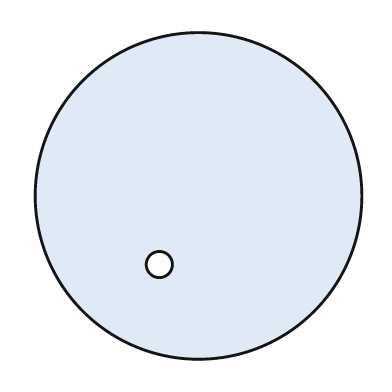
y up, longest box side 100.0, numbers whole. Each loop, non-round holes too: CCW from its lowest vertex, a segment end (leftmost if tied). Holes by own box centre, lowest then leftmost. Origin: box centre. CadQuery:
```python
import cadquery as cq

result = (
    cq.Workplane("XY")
    .moveTo(0.0, 0.0)
    .circle(50.0)
    .moveTo(-12.0, -21.0)
    .circle(4.0)
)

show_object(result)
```